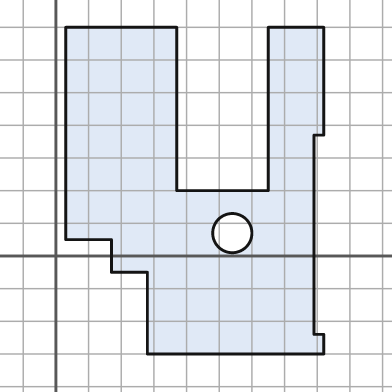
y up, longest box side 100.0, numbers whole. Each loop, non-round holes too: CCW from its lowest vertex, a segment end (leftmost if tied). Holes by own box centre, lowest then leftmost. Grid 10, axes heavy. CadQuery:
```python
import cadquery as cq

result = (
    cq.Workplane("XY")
    .moveTo(28.0, -30.0)
    .lineTo(82.0, -30.0)
    .lineTo(82.0, -24.0)
    .lineTo(79.0, -24.0)
    .lineTo(79.0, 37.0)
    .lineTo(82.0, 37.0)
    .lineTo(82.0, 70.0)
    .lineTo(65.0, 70.0)
    .lineTo(65.0, 20.0)
    .lineTo(37.0, 20.0)
    .lineTo(37.0, 70.0)
    .lineTo(3.0, 70.0)
    .lineTo(3.0, 5.0)
    .lineTo(17.0, 5.0)
    .lineTo(17.0, -5.0)
    .lineTo(28.0, -5.0)
    .close()
    .moveTo(54.0, 7.0)
    .circle(6.0)
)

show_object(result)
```